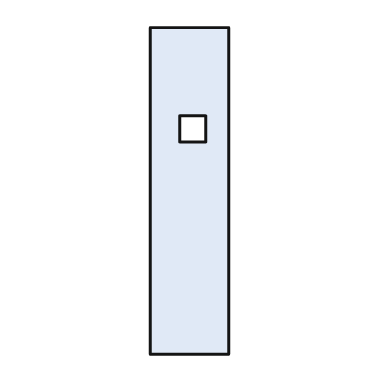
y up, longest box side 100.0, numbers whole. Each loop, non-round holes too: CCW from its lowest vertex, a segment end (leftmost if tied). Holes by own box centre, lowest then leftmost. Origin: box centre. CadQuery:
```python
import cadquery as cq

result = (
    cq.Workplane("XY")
    .moveTo(-12.0, -50.0)
    .lineTo(12.0, -50.0)
    .lineTo(12.0, 50.0)
    .lineTo(-12.0, 50.0)
    .close()
    .moveTo(-3.0, 15.0)
    .lineTo(5.0, 15.0)
    .lineTo(5.0, 23.0)
    .lineTo(-3.0, 23.0)
    .close()
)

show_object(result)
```